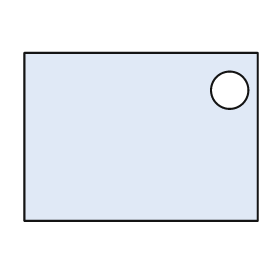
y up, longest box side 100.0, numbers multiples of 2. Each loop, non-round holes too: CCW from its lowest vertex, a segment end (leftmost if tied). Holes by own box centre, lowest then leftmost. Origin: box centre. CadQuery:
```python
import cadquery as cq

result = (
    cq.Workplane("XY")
    .moveTo(-50.0, -36.0)
    .lineTo(50.0, -36.0)
    .lineTo(50.0, 36.0)
    .lineTo(-50.0, 36.0)
    .close()
    .moveTo(38.0, 20.0)
    .circle(8.0)
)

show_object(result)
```